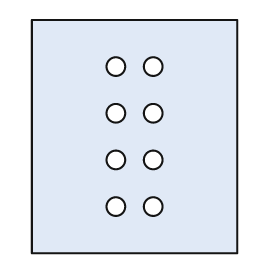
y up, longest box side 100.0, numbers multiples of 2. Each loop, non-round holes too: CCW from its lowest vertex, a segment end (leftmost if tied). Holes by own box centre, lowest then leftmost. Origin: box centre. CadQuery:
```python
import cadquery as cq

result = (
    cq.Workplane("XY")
    .moveTo(-44.0, -50.0)
    .lineTo(44.0, -50.0)
    .lineTo(44.0, 50.0)
    .lineTo(-44.0, 50.0)
    .close()
    .moveTo(-8.0, -30.0)
    .circle(4.0)
    .moveTo(8.0, -30.0)
    .circle(4.0)
    .moveTo(-8.0, -10.0)
    .circle(4.0)
    .moveTo(8.0, -10.0)
    .circle(4.0)
    .moveTo(-8.0, 10.0)
    .circle(4.0)
    .moveTo(8.0, 10.0)
    .circle(4.0)
    .moveTo(-8.0, 30.0)
    .circle(4.0)
    .moveTo(8.0, 30.0)
    .circle(4.0)
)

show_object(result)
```